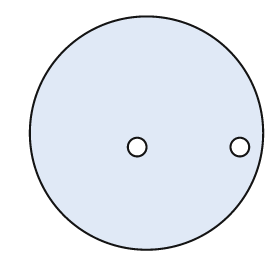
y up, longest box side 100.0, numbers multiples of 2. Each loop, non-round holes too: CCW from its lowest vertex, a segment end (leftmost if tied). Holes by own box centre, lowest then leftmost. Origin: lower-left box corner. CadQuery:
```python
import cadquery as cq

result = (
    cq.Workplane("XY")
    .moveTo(50.0, 50.0)
    .circle(50.0)
    .moveTo(46.0, 44.0)
    .circle(4.0)
    .moveTo(90.0, 44.0)
    .circle(4.0)
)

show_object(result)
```